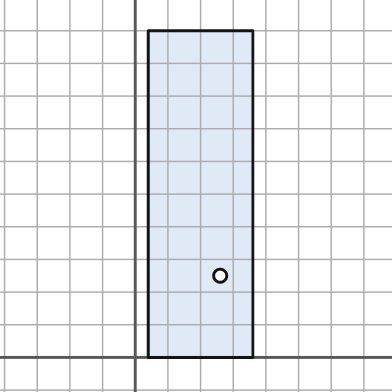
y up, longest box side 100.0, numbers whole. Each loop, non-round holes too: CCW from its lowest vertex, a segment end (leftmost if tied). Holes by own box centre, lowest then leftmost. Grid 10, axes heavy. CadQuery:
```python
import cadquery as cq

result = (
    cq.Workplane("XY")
    .moveTo(4.0, 0.0)
    .lineTo(36.0, 0.0)
    .lineTo(36.0, 100.0)
    .lineTo(4.0, 100.0)
    .close()
    .moveTo(26.0, 25.0)
    .circle(2.0)
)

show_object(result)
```